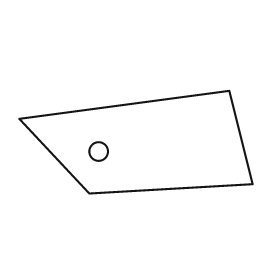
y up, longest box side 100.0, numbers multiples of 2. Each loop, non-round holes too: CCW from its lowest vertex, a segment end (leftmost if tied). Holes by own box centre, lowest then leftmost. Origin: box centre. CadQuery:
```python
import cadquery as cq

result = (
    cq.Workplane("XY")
    .moveTo(-20.0, -22.0)
    .lineTo(50.0, -18.0)
    .lineTo(40.0, 22.0)
    .lineTo(-50.0, 10.0)
    .close()
    .moveTo(-16.0, -4.0)
    .circle(4.0)
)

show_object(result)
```